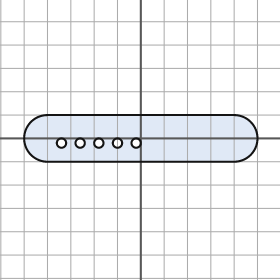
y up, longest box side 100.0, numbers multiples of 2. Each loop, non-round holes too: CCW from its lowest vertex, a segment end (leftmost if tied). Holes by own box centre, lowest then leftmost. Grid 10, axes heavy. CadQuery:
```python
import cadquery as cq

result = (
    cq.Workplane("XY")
    .moveTo(-40.0, -10.0)
    .lineTo(40.0, -10.0)
    .threePointArc((50.0, 0.0), (40.0, 10.0))
    .lineTo(-40.0, 10.0)
    .threePointArc((-50.0, 0.0), (-40.0, -10.0))
    .close()
    .moveTo(-34.0, -2.0)
    .circle(2.0)
    .moveTo(-26.0, -2.0)
    .circle(2.0)
    .moveTo(-18.0, -2.0)
    .circle(2.0)
    .moveTo(-10.0, -2.0)
    .circle(2.0)
    .moveTo(-2.0, -2.0)
    .circle(2.0)
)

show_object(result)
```